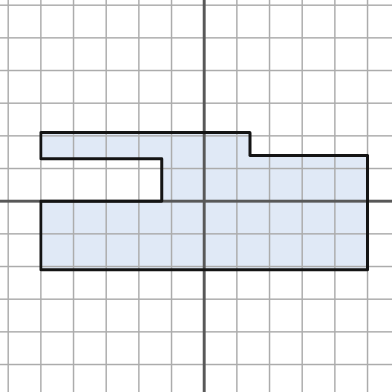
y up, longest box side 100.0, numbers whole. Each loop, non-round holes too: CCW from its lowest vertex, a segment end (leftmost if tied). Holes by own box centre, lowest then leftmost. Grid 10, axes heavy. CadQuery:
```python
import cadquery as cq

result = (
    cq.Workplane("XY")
    .moveTo(-50.0, -21.0)
    .lineTo(50.0, -21.0)
    .lineTo(50.0, 14.0)
    .lineTo(14.0, 14.0)
    .lineTo(14.0, 21.0)
    .lineTo(-50.0, 21.0)
    .lineTo(-50.0, 13.0)
    .lineTo(-13.0, 13.0)
    .lineTo(-13.0, 0.0)
    .lineTo(-50.0, 0.0)
    .close()
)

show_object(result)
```